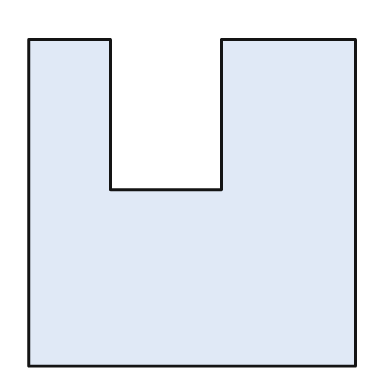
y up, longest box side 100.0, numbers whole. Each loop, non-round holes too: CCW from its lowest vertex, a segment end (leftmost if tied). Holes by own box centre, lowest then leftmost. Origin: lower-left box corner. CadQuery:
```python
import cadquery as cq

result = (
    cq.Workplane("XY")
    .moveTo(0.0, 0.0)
    .lineTo(100.0, 0.0)
    .lineTo(100.0, 100.0)
    .lineTo(59.0, 100.0)
    .lineTo(59.0, 54.0)
    .lineTo(25.0, 54.0)
    .lineTo(25.0, 100.0)
    .lineTo(0.0, 100.0)
    .close()
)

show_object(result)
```